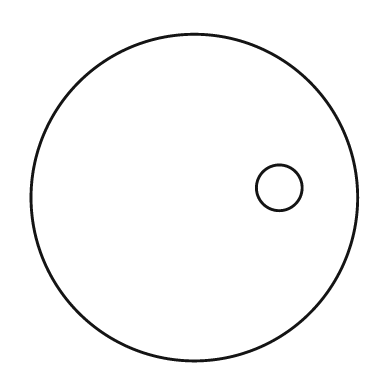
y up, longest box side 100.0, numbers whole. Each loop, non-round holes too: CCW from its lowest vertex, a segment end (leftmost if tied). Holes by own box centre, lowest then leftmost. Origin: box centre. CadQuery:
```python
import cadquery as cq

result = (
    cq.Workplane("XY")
    .moveTo(0.0, 0.0)
    .circle(50.0)
    .moveTo(26.0, 3.0)
    .circle(7.0)
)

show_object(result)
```